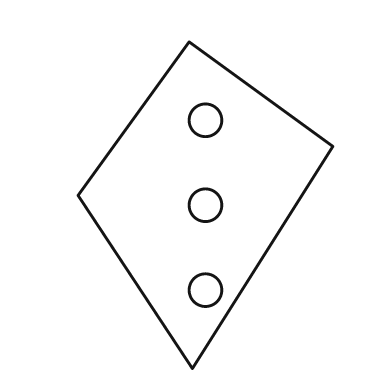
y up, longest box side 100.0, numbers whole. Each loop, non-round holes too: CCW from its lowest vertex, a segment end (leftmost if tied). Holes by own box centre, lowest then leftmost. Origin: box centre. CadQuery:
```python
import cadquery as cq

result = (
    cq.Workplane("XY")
    .moveTo(-4.0, -50.0)
    .lineTo(39.0, 18.0)
    .lineTo(-5.0, 50.0)
    .lineTo(-39.0, 3.0)
    .close()
    .moveTo(0.0, -26.0)
    .circle(5.0)
    .moveTo(0.0, 0.0)
    .circle(5.0)
    .moveTo(0.0, 26.0)
    .circle(5.0)
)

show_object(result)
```